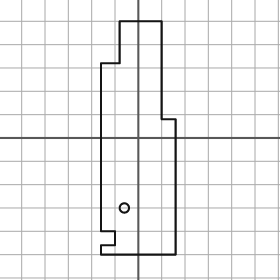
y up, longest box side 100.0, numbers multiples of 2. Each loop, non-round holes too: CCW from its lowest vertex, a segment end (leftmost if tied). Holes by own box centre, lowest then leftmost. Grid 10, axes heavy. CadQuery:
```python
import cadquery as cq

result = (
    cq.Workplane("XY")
    .moveTo(-16.0, -50.0)
    .lineTo(16.0, -50.0)
    .lineTo(16.0, 8.0)
    .lineTo(10.0, 8.0)
    .lineTo(10.0, 50.0)
    .lineTo(-8.0, 50.0)
    .lineTo(-8.0, 32.0)
    .lineTo(-16.0, 32.0)
    .lineTo(-16.0, -40.0)
    .lineTo(-10.0, -40.0)
    .lineTo(-10.0, -46.0)
    .lineTo(-16.0, -46.0)
    .close()
    .moveTo(-6.0, -30.0)
    .circle(2.0)
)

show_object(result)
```